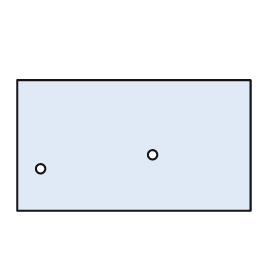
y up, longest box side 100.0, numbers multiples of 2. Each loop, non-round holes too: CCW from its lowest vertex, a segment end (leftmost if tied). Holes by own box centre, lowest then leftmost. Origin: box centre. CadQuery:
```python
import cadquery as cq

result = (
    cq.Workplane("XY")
    .moveTo(-50.0, -28.0)
    .lineTo(50.0, -28.0)
    .lineTo(50.0, 28.0)
    .lineTo(-50.0, 28.0)
    .close()
    .moveTo(-40.0, -10.0)
    .circle(2.0)
    .moveTo(8.0, -4.0)
    .circle(2.0)
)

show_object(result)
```